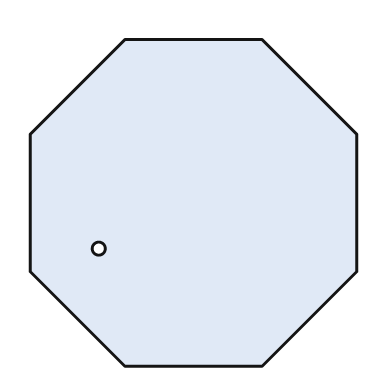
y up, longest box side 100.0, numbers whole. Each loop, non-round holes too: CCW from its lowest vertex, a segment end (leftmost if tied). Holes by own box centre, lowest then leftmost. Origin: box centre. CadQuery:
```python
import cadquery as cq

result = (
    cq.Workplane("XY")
    .moveTo(-21.0, -50.0)
    .lineTo(21.0, -50.0)
    .lineTo(50.0, -21.0)
    .lineTo(50.0, 21.0)
    .lineTo(21.0, 50.0)
    .lineTo(-21.0, 50.0)
    .lineTo(-50.0, 21.0)
    .lineTo(-50.0, -21.0)
    .close()
    .moveTo(-29.0, -14.0)
    .circle(2.0)
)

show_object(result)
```